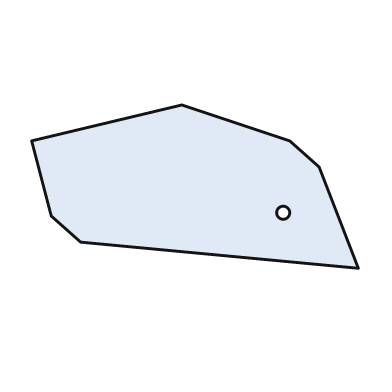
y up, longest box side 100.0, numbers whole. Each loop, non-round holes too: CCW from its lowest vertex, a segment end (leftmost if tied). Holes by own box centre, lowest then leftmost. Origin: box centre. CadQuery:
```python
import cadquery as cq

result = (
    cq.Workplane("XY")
    .moveTo(50.0, -25.0)
    .lineTo(38.0, 6.0)
    .lineTo(29.0, 14.0)
    .lineTo(-4.0, 25.0)
    .lineTo(-50.0, 14.0)
    .lineTo(-44.0, -9.0)
    .lineTo(-35.0, -17.0)
    .close()
    .moveTo(27.0, -8.0)
    .circle(2.0)
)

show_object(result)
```